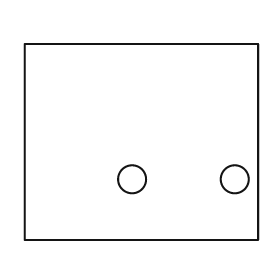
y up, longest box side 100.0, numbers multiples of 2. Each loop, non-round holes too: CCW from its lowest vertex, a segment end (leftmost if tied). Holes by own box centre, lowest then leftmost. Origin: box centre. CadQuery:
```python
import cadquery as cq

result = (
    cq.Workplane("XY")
    .moveTo(-50.0, -42.0)
    .lineTo(50.0, -42.0)
    .lineTo(50.0, 42.0)
    .lineTo(-50.0, 42.0)
    .close()
    .moveTo(-4.0, -16.0)
    .circle(6.0)
    .moveTo(40.0, -16.0)
    .circle(6.0)
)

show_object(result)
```